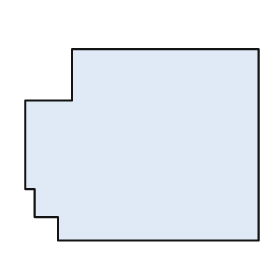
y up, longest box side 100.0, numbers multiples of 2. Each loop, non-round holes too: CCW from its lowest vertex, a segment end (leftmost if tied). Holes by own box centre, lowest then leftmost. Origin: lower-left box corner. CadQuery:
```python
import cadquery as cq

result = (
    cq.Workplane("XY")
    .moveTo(14.0, 0.0)
    .lineTo(100.0, 0.0)
    .lineTo(100.0, 82.0)
    .lineTo(20.0, 82.0)
    .lineTo(20.0, 60.0)
    .lineTo(0.0, 60.0)
    .lineTo(0.0, 22.0)
    .lineTo(4.0, 22.0)
    .lineTo(4.0, 10.0)
    .lineTo(14.0, 10.0)
    .close()
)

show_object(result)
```